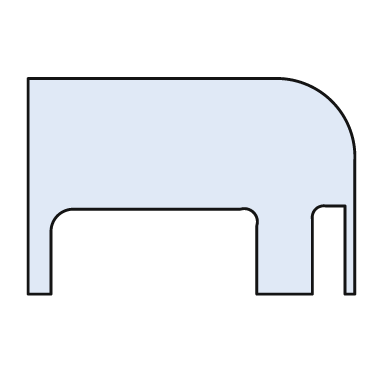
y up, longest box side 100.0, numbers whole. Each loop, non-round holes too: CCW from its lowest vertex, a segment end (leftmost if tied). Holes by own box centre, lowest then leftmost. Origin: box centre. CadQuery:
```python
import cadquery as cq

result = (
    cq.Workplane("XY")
    .moveTo(-50.0, -33.0)
    .lineTo(-43.0, -33.0)
    .lineTo(-43.0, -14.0)
    .threePointArc((-41.0, -9.0), (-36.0, -7.0))
    .lineTo(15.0, -7.0)
    .threePointArc((19.0, -8.0), (20.0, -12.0))
    .lineTo(20.0, -33.0)
    .lineTo(37.0, -33.0)
    .lineTo(37.0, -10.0)
    .threePointArc((38.0, -7.0), (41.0, -6.0))
    .lineTo(47.0, -6.0)
    .lineTo(47.0, -33.0)
    .lineTo(50.0, -33.0)
    .lineTo(50.0, 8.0)
    .threePointArc((43.0, 26.0), (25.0, 33.0))
    .lineTo(-50.0, 33.0)
    .close()
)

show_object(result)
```